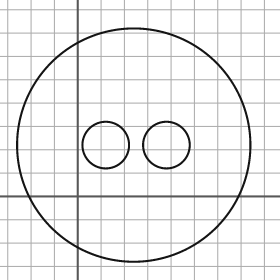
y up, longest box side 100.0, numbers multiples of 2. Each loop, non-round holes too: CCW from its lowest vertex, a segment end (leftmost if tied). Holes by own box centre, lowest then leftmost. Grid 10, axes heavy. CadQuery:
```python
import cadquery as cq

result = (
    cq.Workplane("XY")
    .moveTo(24.0, 22.0)
    .circle(50.0)
    .moveTo(12.0, 22.0)
    .circle(10.0)
    .moveTo(38.0, 22.0)
    .circle(10.0)
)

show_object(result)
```